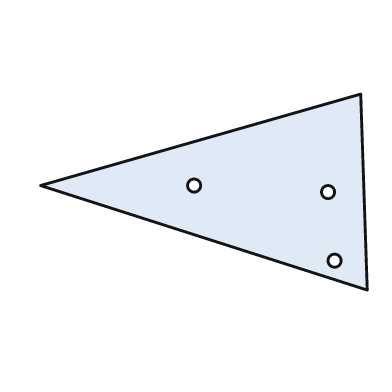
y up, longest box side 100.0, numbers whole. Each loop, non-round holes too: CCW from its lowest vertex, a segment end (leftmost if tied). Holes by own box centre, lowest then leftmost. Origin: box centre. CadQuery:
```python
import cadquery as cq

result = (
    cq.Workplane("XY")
    .moveTo(50.0, -30.0)
    .lineTo(48.0, 30.0)
    .lineTo(-50.0, 2.0)
    .close()
    .moveTo(40.0, -21.0)
    .circle(2.0)
    .moveTo(38.0, 0.0)
    .circle(2.0)
    .moveTo(-3.0, 2.0)
    .circle(2.0)
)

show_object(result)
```